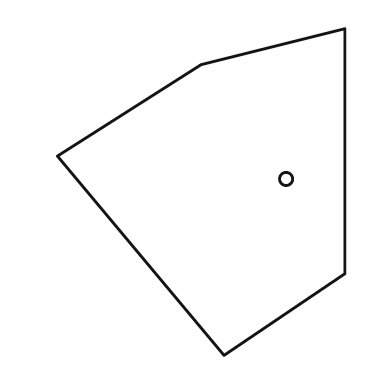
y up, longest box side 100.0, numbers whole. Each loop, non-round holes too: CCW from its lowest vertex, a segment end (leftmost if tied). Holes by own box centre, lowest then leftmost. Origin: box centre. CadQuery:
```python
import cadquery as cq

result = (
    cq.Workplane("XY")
    .moveTo(7.0, -50.0)
    .lineTo(44.0, -25.0)
    .lineTo(44.0, 50.0)
    .lineTo(0.0, 39.0)
    .lineTo(-44.0, 11.0)
    .close()
    .moveTo(26.0, 4.0)
    .circle(2.0)
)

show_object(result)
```